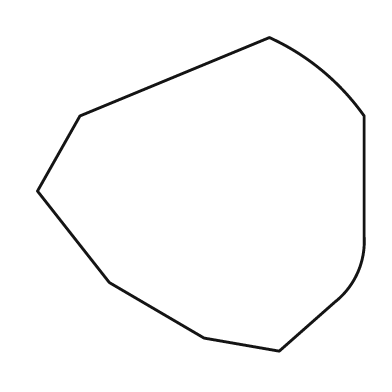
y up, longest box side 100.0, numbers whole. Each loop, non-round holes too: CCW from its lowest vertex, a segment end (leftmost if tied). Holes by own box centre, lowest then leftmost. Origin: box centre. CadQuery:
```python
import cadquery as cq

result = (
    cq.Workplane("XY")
    .moveTo(24.0, -48.0)
    .lineTo(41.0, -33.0)
    .threePointArc((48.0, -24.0), (50.0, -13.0))
    .lineTo(50.0, 24.0)
    .threePointArc((37.0, 38.0), (21.0, 48.0))
    .lineTo(-37.0, 24.0)
    .lineTo(-50.0, 1.0)
    .lineTo(-28.0, -27.0)
    .lineTo(1.0, -44.0)
    .close()
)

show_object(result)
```